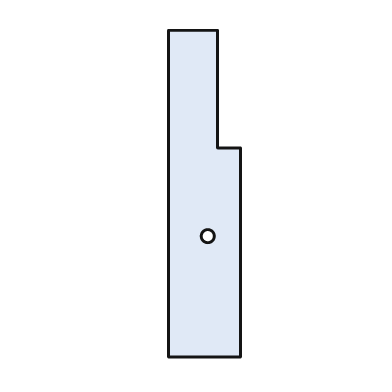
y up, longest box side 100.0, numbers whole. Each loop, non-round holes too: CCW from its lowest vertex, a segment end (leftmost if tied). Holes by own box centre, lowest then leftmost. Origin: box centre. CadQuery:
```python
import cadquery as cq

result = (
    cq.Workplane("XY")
    .moveTo(-11.0, -50.0)
    .lineTo(11.0, -50.0)
    .lineTo(11.0, 14.0)
    .lineTo(4.0, 14.0)
    .lineTo(4.0, 50.0)
    .lineTo(-11.0, 50.0)
    .close()
    .moveTo(1.0, -13.0)
    .circle(2.0)
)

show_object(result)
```